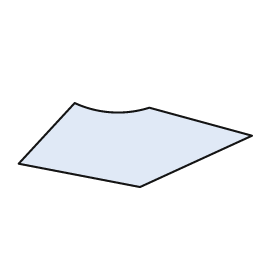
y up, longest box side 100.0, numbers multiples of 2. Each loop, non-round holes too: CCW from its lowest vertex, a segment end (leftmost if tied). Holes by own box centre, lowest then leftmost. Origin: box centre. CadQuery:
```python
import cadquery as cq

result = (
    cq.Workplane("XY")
    .moveTo(2.0, -18.0)
    .lineTo(50.0, 4.0)
    .lineTo(6.0, 16.0)
    .threePointArc((-10.0, 14.0), (-26.0, 18.0))
    .lineTo(-50.0, -8.0)
    .close()
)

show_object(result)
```